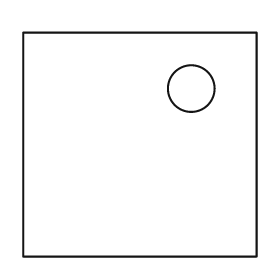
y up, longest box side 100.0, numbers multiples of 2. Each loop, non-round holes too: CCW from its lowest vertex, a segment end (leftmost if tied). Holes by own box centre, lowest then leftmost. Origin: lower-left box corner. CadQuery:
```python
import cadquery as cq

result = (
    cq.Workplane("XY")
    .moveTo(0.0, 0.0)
    .lineTo(100.0, 0.0)
    .lineTo(100.0, 96.0)
    .lineTo(0.0, 96.0)
    .close()
    .moveTo(72.0, 72.0)
    .circle(10.0)
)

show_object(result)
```